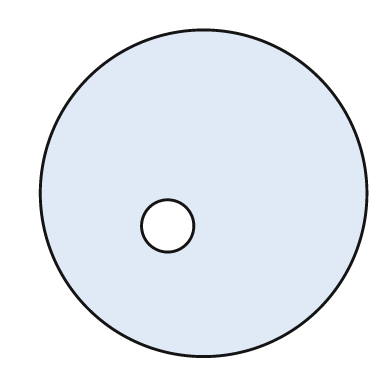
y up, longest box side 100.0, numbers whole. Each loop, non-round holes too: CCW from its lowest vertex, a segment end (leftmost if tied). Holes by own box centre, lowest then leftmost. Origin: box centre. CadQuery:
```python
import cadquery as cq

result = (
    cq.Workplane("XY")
    .moveTo(0.0, 0.0)
    .circle(50.0)
    .moveTo(-11.0, -10.0)
    .circle(8.0)
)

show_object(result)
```